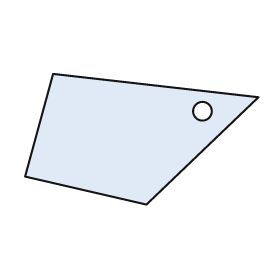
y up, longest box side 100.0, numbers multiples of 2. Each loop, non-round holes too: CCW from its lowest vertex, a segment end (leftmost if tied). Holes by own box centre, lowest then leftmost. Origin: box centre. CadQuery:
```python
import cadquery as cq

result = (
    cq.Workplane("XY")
    .moveTo(2.0, -28.0)
    .lineTo(50.0, 18.0)
    .lineTo(-38.0, 28.0)
    .lineTo(-50.0, -16.0)
    .close()
    .moveTo(26.0, 12.0)
    .circle(4.0)
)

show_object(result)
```